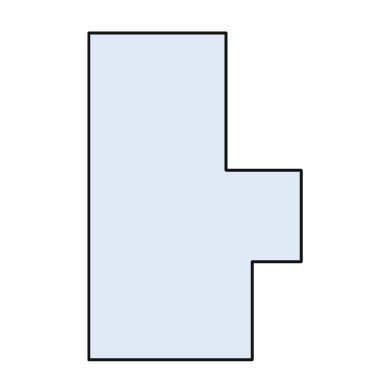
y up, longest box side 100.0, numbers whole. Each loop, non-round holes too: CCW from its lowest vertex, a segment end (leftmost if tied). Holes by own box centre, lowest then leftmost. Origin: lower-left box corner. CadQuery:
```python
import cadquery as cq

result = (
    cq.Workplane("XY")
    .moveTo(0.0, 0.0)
    .lineTo(50.0, 0.0)
    .lineTo(50.0, 30.0)
    .lineTo(65.0, 30.0)
    .lineTo(65.0, 58.0)
    .lineTo(42.0, 58.0)
    .lineTo(42.0, 100.0)
    .lineTo(0.0, 100.0)
    .close()
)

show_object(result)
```